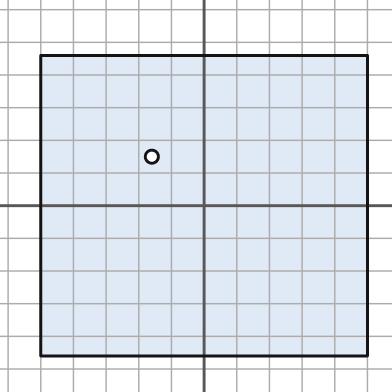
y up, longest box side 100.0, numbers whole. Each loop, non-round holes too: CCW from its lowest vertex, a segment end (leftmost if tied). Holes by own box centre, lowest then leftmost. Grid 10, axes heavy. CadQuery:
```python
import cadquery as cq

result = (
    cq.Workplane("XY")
    .moveTo(-50.0, -46.0)
    .lineTo(50.0, -46.0)
    .lineTo(50.0, 46.0)
    .lineTo(-50.0, 46.0)
    .close()
    .moveTo(-16.0, 15.0)
    .circle(2.0)
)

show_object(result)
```